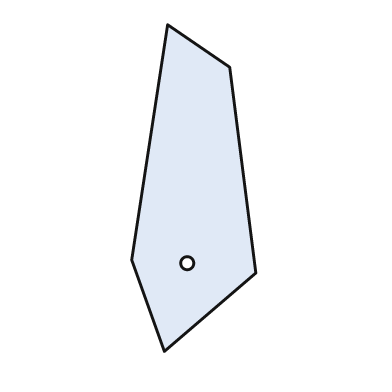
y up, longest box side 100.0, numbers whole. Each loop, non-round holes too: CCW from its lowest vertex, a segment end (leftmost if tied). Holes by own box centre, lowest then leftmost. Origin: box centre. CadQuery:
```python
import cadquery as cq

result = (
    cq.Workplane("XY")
    .moveTo(-9.0, -50.0)
    .lineTo(19.0, -26.0)
    .lineTo(11.0, 37.0)
    .lineTo(-8.0, 50.0)
    .lineTo(-19.0, -22.0)
    .close()
    .moveTo(-2.0, -23.0)
    .circle(2.0)
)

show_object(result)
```